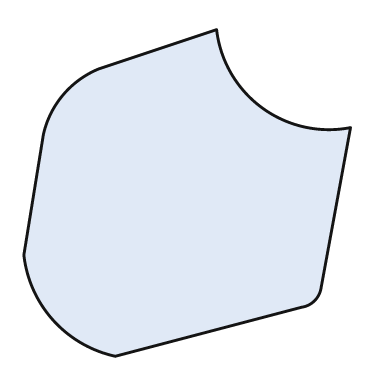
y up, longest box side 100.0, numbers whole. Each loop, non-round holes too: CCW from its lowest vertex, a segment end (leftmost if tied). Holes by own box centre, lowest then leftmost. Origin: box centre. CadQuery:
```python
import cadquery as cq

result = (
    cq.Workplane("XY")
    .moveTo(-22.0, -50.0)
    .lineTo(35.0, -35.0)
    .threePointArc((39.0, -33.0), (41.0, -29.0))
    .lineTo(50.0, 20.0)
    .threePointArc((23.0, 26.0), (9.0, 50.0))
    .lineTo(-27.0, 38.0)
    .threePointArc((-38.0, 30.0), (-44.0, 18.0))
    .lineTo(-50.0, -19.0)
    .threePointArc((-41.0, -39.0), (-22.0, -50.0))
    .close()
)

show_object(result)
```